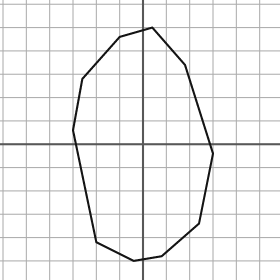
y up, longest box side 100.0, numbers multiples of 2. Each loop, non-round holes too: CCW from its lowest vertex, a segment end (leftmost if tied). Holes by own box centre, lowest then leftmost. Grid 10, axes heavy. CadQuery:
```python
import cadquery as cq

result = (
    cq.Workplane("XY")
    .moveTo(-4.0, -50.0)
    .lineTo(8.0, -48.0)
    .lineTo(24.0, -34.0)
    .lineTo(30.0, -4.0)
    .lineTo(18.0, 34.0)
    .lineTo(4.0, 50.0)
    .lineTo(-10.0, 46.0)
    .lineTo(-26.0, 28.0)
    .lineTo(-30.0, 6.0)
    .lineTo(-20.0, -42.0)
    .close()
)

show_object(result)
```